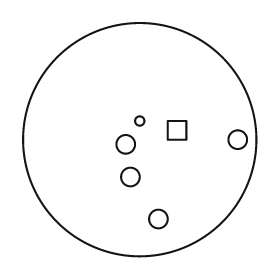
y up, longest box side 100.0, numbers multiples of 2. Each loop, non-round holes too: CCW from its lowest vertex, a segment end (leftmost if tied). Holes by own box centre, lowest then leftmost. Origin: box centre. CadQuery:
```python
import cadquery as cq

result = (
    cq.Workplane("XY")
    .moveTo(0.0, 0.0)
    .circle(50.0)
    .moveTo(8.0, -34.0)
    .circle(4.0)
    .moveTo(-4.0, -16.0)
    .circle(4.0)
    .moveTo(-6.0, -2.0)
    .circle(4.0)
    .moveTo(42.0, 0.0)
    .circle(4.0)
    .moveTo(12.0, 0.0)
    .lineTo(20.0, 0.0)
    .lineTo(20.0, 8.0)
    .lineTo(12.0, 8.0)
    .close()
    .moveTo(0.0, 8.0)
    .circle(2.0)
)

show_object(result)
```